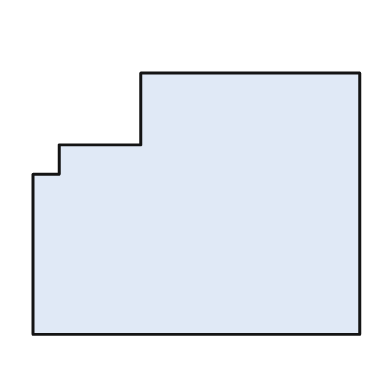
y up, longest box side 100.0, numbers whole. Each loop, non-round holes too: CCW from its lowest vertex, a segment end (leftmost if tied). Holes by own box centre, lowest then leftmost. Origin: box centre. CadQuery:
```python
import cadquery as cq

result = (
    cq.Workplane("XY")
    .moveTo(-50.0, -40.0)
    .lineTo(50.0, -40.0)
    .lineTo(50.0, 40.0)
    .lineTo(-17.0, 40.0)
    .lineTo(-17.0, 18.0)
    .lineTo(-42.0, 18.0)
    .lineTo(-42.0, 9.0)
    .lineTo(-50.0, 9.0)
    .close()
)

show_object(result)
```